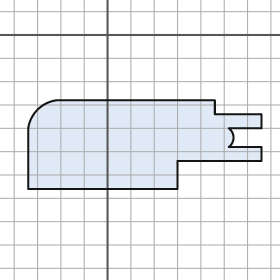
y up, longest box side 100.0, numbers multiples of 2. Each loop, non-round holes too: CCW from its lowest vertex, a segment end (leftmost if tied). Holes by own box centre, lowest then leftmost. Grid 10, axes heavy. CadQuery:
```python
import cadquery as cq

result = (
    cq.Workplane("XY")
    .moveTo(-34.0, -66.0)
    .lineTo(30.0, -66.0)
    .lineTo(30.0, -54.0)
    .lineTo(66.0, -54.0)
    .lineTo(66.0, -48.0)
    .lineTo(52.0, -48.0)
    .threePointArc((54.0, -44.0), (52.0, -40.0))
    .lineTo(66.0, -40.0)
    .lineTo(66.0, -34.0)
    .lineTo(46.0, -34.0)
    .lineTo(46.0, -28.0)
    .lineTo(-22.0, -28.0)
    .threePointArc((-30.0, -32.0), (-34.0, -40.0))
    .close()
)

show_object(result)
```